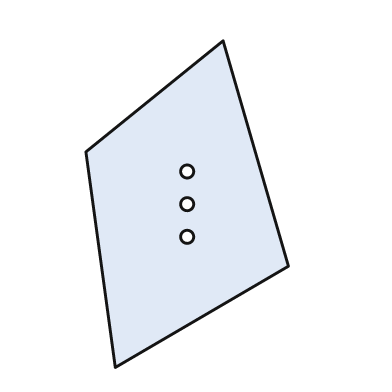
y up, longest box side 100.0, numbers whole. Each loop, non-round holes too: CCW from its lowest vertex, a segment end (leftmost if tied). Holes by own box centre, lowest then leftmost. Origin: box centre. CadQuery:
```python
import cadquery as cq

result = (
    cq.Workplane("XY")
    .moveTo(-22.0, -50.0)
    .lineTo(31.0, -19.0)
    .lineTo(11.0, 50.0)
    .lineTo(-31.0, 16.0)
    .close()
    .moveTo(0.0, -10.0)
    .circle(2.0)
    .moveTo(0.0, 0.0)
    .circle(2.0)
    .moveTo(0.0, 10.0)
    .circle(2.0)
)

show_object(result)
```